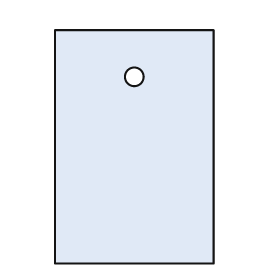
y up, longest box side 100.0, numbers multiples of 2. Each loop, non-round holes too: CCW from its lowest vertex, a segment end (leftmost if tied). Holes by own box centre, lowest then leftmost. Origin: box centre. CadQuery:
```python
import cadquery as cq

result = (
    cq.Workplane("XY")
    .moveTo(-34.0, -50.0)
    .lineTo(34.0, -50.0)
    .lineTo(34.0, 50.0)
    .lineTo(-34.0, 50.0)
    .close()
    .moveTo(0.0, 30.0)
    .circle(4.0)
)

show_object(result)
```